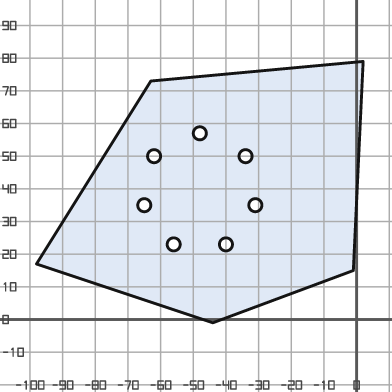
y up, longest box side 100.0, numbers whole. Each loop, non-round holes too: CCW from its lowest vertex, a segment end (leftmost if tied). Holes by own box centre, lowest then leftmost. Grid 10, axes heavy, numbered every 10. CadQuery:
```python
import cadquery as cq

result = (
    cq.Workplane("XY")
    .moveTo(-44.0, -1.0)
    .lineTo(-1.0, 15.0)
    .lineTo(2.0, 79.0)
    .lineTo(-63.0, 73.0)
    .lineTo(-98.0, 17.0)
    .close()
    .moveTo(-56.0, 23.0)
    .circle(2.0)
    .moveTo(-40.0, 23.0)
    .circle(2.0)
    .moveTo(-65.0, 35.0)
    .circle(2.0)
    .moveTo(-31.0, 35.0)
    .circle(2.0)
    .moveTo(-62.0, 50.0)
    .circle(2.0)
    .moveTo(-34.0, 50.0)
    .circle(2.0)
    .moveTo(-48.0, 57.0)
    .circle(2.0)
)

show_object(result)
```